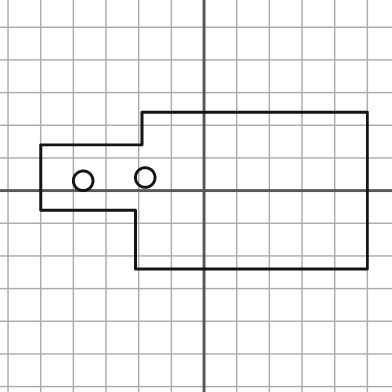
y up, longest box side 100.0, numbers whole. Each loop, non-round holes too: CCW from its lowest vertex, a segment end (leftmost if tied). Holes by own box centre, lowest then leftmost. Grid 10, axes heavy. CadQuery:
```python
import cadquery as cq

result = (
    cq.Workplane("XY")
    .moveTo(-21.0, -24.0)
    .lineTo(50.0, -24.0)
    .lineTo(50.0, 24.0)
    .lineTo(-19.0, 24.0)
    .lineTo(-19.0, 14.0)
    .lineTo(-50.0, 14.0)
    .lineTo(-50.0, -6.0)
    .lineTo(-21.0, -6.0)
    .close()
    .moveTo(-37.0, 3.0)
    .circle(3.0)
    .moveTo(-18.0, 4.0)
    .circle(3.0)
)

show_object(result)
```